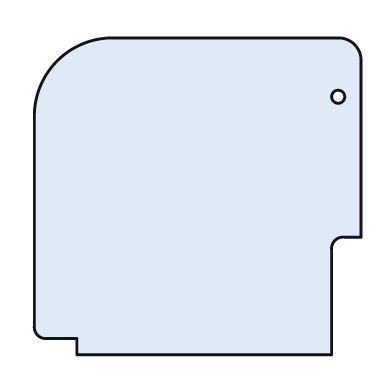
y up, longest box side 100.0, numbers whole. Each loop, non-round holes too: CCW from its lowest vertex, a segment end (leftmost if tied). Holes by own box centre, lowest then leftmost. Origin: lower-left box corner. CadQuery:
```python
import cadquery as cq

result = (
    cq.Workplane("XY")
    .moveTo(13.0, 0.0)
    .lineTo(91.0, 0.0)
    .lineTo(91.0, 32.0)
    .threePointArc((92.0, 35.0), (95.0, 36.0))
    .lineTo(100.0, 36.0)
    .lineTo(100.0, 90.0)
    .threePointArc((98.0, 95.0), (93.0, 97.0))
    .lineTo(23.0, 97.0)
    .threePointArc((7.0, 90.0), (0.0, 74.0))
    .lineTo(0.0, 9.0)
    .threePointArc((1.0, 6.0), (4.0, 5.0))
    .lineTo(13.0, 5.0)
    .close()
    .moveTo(93.0, 79.0)
    .circle(2.0)
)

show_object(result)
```